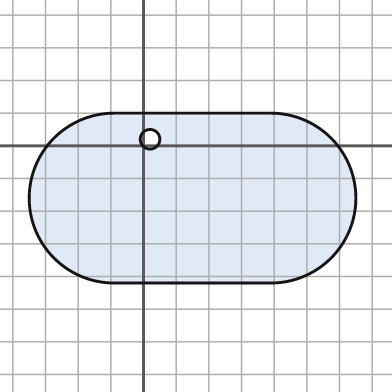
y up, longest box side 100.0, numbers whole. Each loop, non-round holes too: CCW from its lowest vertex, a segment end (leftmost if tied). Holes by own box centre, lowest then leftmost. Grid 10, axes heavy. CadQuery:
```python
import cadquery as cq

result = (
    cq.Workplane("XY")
    .moveTo(-9.0, -42.0)
    .lineTo(39.0, -42.0)
    .threePointArc((65.0, -16.0), (39.0, 10.0))
    .lineTo(-9.0, 10.0)
    .threePointArc((-35.0, -16.0), (-9.0, -42.0))
    .close()
    .moveTo(2.0, 2.0)
    .circle(3.0)
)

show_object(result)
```